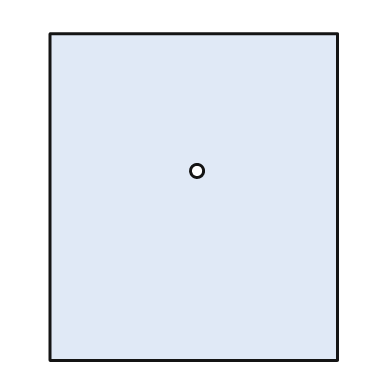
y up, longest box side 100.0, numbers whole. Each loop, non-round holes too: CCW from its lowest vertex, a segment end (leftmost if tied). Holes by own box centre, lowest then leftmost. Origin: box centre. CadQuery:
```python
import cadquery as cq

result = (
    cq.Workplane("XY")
    .moveTo(-44.0, -50.0)
    .lineTo(44.0, -50.0)
    .lineTo(44.0, 50.0)
    .lineTo(-44.0, 50.0)
    .close()
    .moveTo(1.0, 8.0)
    .circle(2.0)
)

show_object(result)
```